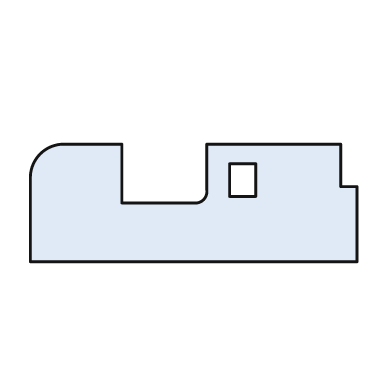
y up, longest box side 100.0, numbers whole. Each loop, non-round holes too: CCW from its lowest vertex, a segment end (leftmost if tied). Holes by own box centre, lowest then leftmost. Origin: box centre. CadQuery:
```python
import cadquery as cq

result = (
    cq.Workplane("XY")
    .moveTo(-50.0, -18.0)
    .lineTo(50.0, -18.0)
    .lineTo(50.0, 5.0)
    .lineTo(45.0, 5.0)
    .lineTo(45.0, 18.0)
    .lineTo(4.0, 18.0)
    .lineTo(4.0, 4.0)
    .threePointArc((3.0, 1.0), (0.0, 0.0))
    .lineTo(-22.0, 0.0)
    .lineTo(-22.0, 18.0)
    .lineTo(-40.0, 18.0)
    .threePointArc((-47.0, 15.0), (-50.0, 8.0))
    .close()
    .moveTo(11.0, 2.0)
    .lineTo(19.0, 2.0)
    .lineTo(19.0, 12.0)
    .lineTo(11.0, 12.0)
    .close()
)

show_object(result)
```